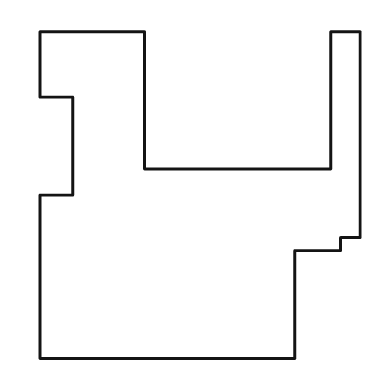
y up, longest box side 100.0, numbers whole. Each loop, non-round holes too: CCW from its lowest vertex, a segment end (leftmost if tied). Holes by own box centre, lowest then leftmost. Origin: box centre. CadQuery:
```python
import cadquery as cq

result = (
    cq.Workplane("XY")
    .moveTo(-49.0, -50.0)
    .lineTo(29.0, -50.0)
    .lineTo(29.0, -17.0)
    .lineTo(43.0, -17.0)
    .lineTo(43.0, -13.0)
    .lineTo(49.0, -13.0)
    .lineTo(49.0, 50.0)
    .lineTo(40.0, 50.0)
    .lineTo(40.0, 8.0)
    .lineTo(-17.0, 8.0)
    .lineTo(-17.0, 50.0)
    .lineTo(-49.0, 50.0)
    .lineTo(-49.0, 30.0)
    .lineTo(-39.0, 30.0)
    .lineTo(-39.0, 0.0)
    .lineTo(-49.0, 0.0)
    .close()
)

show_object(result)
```